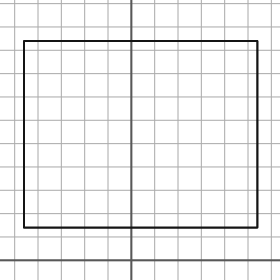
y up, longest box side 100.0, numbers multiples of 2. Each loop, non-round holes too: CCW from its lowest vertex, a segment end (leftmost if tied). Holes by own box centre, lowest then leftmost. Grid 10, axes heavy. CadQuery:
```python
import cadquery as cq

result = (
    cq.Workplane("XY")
    .moveTo(-46.0, 14.0)
    .lineTo(54.0, 14.0)
    .lineTo(54.0, 94.0)
    .lineTo(-46.0, 94.0)
    .close()
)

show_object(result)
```